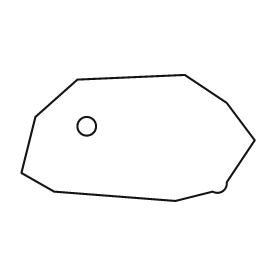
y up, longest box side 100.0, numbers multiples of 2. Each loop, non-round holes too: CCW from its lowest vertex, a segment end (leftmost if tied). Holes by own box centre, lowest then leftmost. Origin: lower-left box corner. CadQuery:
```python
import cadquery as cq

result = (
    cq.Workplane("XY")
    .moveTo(66.0, 0.0)
    .lineTo(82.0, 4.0)
    .threePointArc((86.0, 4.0), (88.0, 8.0))
    .lineTo(100.0, 26.0)
    .lineTo(88.0, 42.0)
    .lineTo(70.0, 54.0)
    .lineTo(24.0, 52.0)
    .lineTo(6.0, 36.0)
    .lineTo(0.0, 12.0)
    .lineTo(14.0, 4.0)
    .close()
    .moveTo(28.0, 32.0)
    .circle(4.0)
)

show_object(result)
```